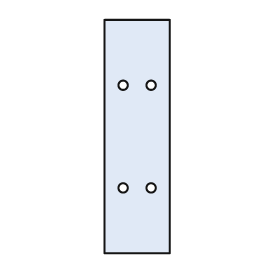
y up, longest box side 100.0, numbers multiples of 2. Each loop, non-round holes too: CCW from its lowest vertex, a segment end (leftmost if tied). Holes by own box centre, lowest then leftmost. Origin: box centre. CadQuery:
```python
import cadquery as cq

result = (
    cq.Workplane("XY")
    .moveTo(-14.0, -50.0)
    .lineTo(14.0, -50.0)
    .lineTo(14.0, 50.0)
    .lineTo(-14.0, 50.0)
    .close()
    .moveTo(-6.0, -22.0)
    .circle(2.0)
    .moveTo(6.0, -22.0)
    .circle(2.0)
    .moveTo(-6.0, 22.0)
    .circle(2.0)
    .moveTo(6.0, 22.0)
    .circle(2.0)
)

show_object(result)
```